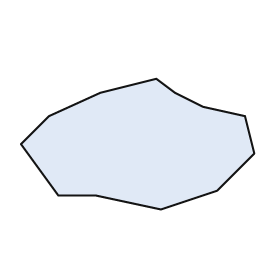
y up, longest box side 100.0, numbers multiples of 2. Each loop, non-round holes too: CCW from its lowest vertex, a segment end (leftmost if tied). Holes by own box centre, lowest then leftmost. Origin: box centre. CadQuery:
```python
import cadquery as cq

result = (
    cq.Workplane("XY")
    .moveTo(10.0, -28.0)
    .lineTo(34.0, -20.0)
    .lineTo(50.0, -4.0)
    .lineTo(46.0, 12.0)
    .lineTo(28.0, 16.0)
    .lineTo(16.0, 22.0)
    .lineTo(8.0, 28.0)
    .lineTo(-16.0, 22.0)
    .lineTo(-38.0, 12.0)
    .lineTo(-50.0, 0.0)
    .lineTo(-34.0, -22.0)
    .lineTo(-18.0, -22.0)
    .close()
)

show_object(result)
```